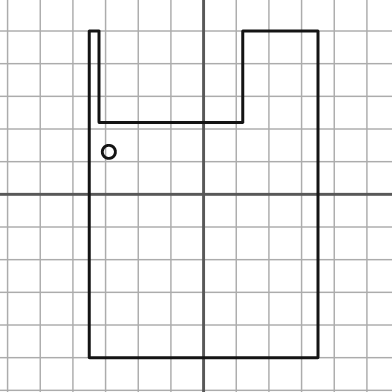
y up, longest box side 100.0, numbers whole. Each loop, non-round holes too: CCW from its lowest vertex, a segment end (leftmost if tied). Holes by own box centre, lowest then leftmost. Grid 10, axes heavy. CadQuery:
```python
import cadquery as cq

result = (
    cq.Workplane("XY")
    .moveTo(-35.0, -50.0)
    .lineTo(35.0, -50.0)
    .lineTo(35.0, 50.0)
    .lineTo(12.0, 50.0)
    .lineTo(12.0, 22.0)
    .lineTo(-32.0, 22.0)
    .lineTo(-32.0, 50.0)
    .lineTo(-35.0, 50.0)
    .close()
    .moveTo(-29.0, 13.0)
    .circle(2.0)
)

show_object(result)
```